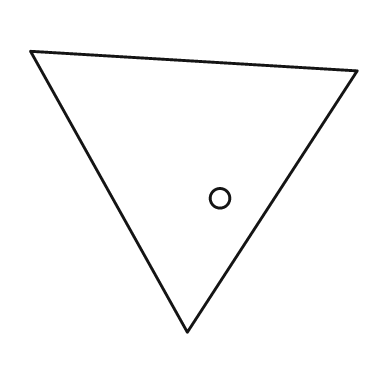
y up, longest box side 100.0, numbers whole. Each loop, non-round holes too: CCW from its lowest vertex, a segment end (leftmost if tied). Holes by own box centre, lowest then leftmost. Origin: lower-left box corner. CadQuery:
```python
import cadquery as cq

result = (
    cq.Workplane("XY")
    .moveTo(48.0, 0.0)
    .lineTo(100.0, 80.0)
    .lineTo(0.0, 86.0)
    .close()
    .moveTo(58.0, 41.0)
    .circle(3.0)
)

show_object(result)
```